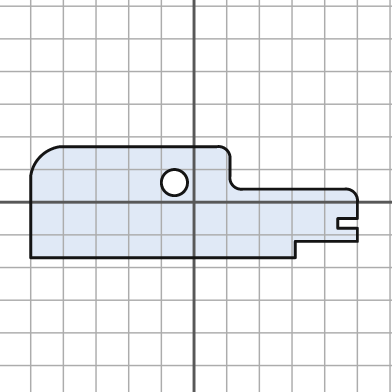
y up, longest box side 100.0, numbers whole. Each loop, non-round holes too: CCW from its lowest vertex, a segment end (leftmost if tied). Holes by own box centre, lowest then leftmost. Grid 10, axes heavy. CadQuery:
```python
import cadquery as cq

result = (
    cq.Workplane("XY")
    .moveTo(-50.0, -17.0)
    .lineTo(31.0, -17.0)
    .lineTo(31.0, -12.0)
    .lineTo(50.0, -12.0)
    .lineTo(50.0, -8.0)
    .lineTo(44.0, -8.0)
    .lineTo(44.0, -5.0)
    .lineTo(50.0, -5.0)
    .lineTo(50.0, 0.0)
    .threePointArc((49.0, 3.0), (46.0, 4.0))
    .lineTo(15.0, 4.0)
    .threePointArc((12.0, 5.0), (11.0, 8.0))
    .lineTo(11.0, 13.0)
    .threePointArc((10.0, 16.0), (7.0, 17.0))
    .lineTo(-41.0, 17.0)
    .threePointArc((-47.0, 14.0), (-50.0, 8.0))
    .close()
    .moveTo(-6.0, 6.0)
    .circle(4.0)
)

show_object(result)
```